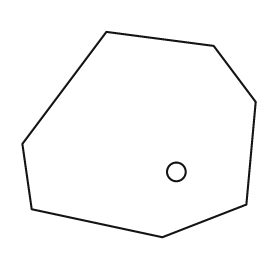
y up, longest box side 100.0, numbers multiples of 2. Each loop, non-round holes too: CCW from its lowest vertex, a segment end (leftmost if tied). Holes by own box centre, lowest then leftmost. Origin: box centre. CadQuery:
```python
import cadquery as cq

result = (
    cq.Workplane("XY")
    .moveTo(10.0, -44.0)
    .lineTo(46.0, -30.0)
    .lineTo(50.0, 14.0)
    .lineTo(32.0, 38.0)
    .lineTo(-14.0, 44.0)
    .lineTo(-50.0, -4.0)
    .lineTo(-46.0, -32.0)
    .close()
    .moveTo(16.0, -16.0)
    .circle(4.0)
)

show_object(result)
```